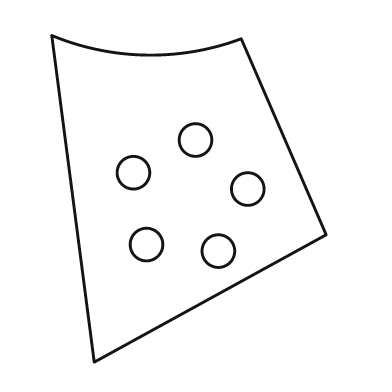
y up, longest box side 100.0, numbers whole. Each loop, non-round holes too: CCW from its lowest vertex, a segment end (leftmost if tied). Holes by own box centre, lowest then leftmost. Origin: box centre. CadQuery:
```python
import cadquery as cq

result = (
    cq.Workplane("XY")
    .moveTo(-29.0, -50.0)
    .lineTo(42.0, -11.0)
    .lineTo(16.0, 49.0)
    .threePointArc((-13.0, 44.0), (-42.0, 50.0))
    .close()
    .moveTo(9.0, -16.0)
    .circle(5.0)
    .moveTo(-13.0, -14.0)
    .circle(5.0)
    .moveTo(18.0, 3.0)
    .circle(5.0)
    .moveTo(-17.0, 8.0)
    .circle(5.0)
    .moveTo(2.0, 18.0)
    .circle(5.0)
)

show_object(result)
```